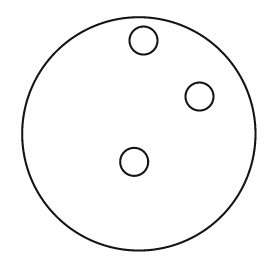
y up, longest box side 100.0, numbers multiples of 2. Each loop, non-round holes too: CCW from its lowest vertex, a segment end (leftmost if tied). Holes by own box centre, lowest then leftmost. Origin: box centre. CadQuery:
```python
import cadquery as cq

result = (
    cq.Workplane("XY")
    .moveTo(0.0, 0.0)
    .circle(50.0)
    .moveTo(-2.0, -12.0)
    .circle(6.0)
    .moveTo(26.0, 16.0)
    .circle(6.0)
    .moveTo(2.0, 40.0)
    .circle(6.0)
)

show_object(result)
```